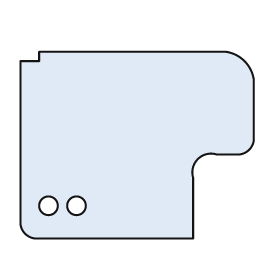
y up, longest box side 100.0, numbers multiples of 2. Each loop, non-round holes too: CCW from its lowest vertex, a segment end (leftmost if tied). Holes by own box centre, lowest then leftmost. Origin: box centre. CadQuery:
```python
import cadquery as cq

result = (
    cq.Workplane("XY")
    .moveTo(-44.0, -40.0)
    .lineTo(24.0, -40.0)
    .lineTo(24.0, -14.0)
    .threePointArc((26.0, -6.0), (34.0, -4.0))
    .lineTo(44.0, -4.0)
    .threePointArc((48.0, -2.0), (50.0, 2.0))
    .lineTo(50.0, 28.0)
    .threePointArc((46.0, 36.0), (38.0, 40.0))
    .lineTo(-42.0, 40.0)
    .lineTo(-42.0, 36.0)
    .lineTo(-50.0, 36.0)
    .lineTo(-50.0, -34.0)
    .threePointArc((-48.0, -38.0), (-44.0, -40.0))
    .close()
    .moveTo(-38.0, -26.0)
    .circle(4.0)
    .moveTo(-26.0, -26.0)
    .circle(4.0)
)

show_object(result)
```